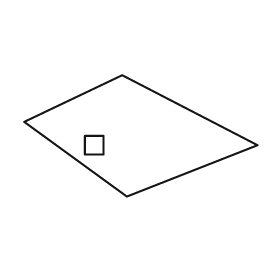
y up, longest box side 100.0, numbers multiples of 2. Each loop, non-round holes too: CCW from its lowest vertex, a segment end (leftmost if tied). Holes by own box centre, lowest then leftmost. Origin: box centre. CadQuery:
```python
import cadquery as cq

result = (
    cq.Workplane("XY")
    .moveTo(-6.0, -26.0)
    .lineTo(50.0, -4.0)
    .lineTo(-8.0, 26.0)
    .lineTo(-50.0, 6.0)
    .close()
    .moveTo(-24.0, -8.0)
    .lineTo(-16.0, -8.0)
    .lineTo(-16.0, 0.0)
    .lineTo(-24.0, 0.0)
    .close()
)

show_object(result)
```